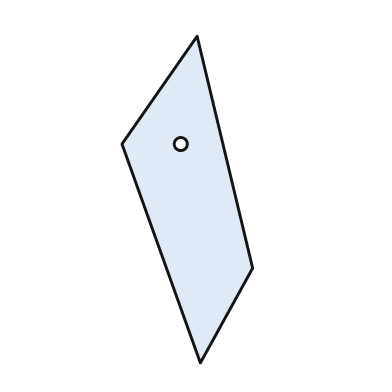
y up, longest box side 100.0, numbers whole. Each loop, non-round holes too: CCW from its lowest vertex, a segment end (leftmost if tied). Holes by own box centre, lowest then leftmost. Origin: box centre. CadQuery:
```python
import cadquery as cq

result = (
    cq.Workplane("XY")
    .moveTo(4.0, -50.0)
    .lineTo(20.0, -21.0)
    .lineTo(3.0, 50.0)
    .lineTo(-20.0, 17.0)
    .close()
    .moveTo(-2.0, 17.0)
    .circle(2.0)
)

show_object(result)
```